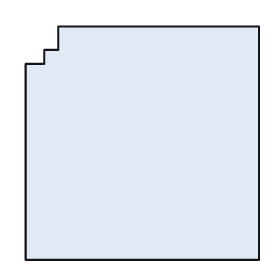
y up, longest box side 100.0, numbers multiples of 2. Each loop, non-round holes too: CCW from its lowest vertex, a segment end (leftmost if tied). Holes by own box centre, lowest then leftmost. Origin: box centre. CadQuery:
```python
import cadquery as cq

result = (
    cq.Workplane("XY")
    .moveTo(-50.0, -50.0)
    .lineTo(50.0, -50.0)
    .lineTo(50.0, 50.0)
    .lineTo(-36.0, 50.0)
    .lineTo(-36.0, 40.0)
    .lineTo(-42.0, 40.0)
    .lineTo(-42.0, 34.0)
    .lineTo(-50.0, 34.0)
    .close()
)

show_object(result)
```